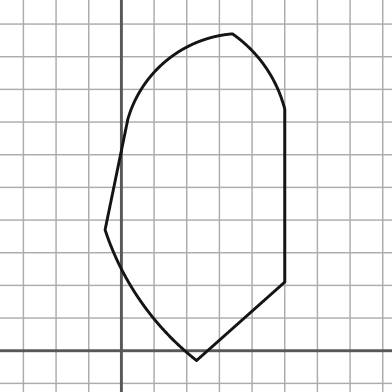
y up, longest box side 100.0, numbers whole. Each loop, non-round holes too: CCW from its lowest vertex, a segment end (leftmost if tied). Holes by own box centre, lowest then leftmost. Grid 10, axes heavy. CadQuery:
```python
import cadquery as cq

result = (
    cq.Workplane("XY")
    .moveTo(23.0, -3.0)
    .lineTo(50.0, 21.0)
    .lineTo(50.0, 74.0)
    .threePointArc((44.0, 87.0), (34.0, 97.0))
    .threePointArc((14.0, 89.0), (2.0, 71.0))
    .lineTo(-5.0, 37.0)
    .threePointArc((6.0, 15.0), (23.0, -3.0))
    .close()
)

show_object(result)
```